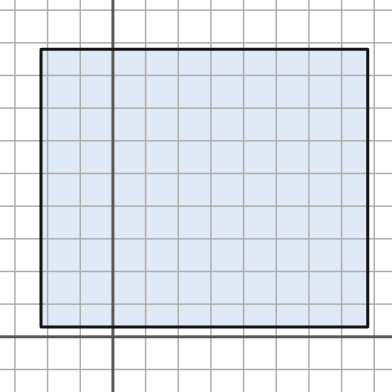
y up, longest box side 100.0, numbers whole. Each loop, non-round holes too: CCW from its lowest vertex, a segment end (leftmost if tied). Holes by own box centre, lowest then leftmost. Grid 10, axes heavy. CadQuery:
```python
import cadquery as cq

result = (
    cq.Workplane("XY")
    .moveTo(-22.0, 3.0)
    .lineTo(78.0, 3.0)
    .lineTo(78.0, 88.0)
    .lineTo(-22.0, 88.0)
    .close()
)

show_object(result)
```